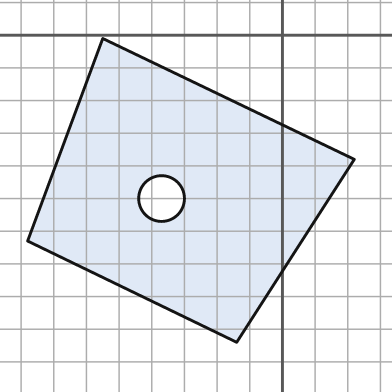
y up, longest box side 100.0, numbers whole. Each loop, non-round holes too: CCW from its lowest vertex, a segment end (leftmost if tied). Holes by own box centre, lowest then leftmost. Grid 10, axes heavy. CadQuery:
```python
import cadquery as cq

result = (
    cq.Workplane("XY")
    .moveTo(-14.0, -94.0)
    .lineTo(22.0, -38.0)
    .lineTo(-55.0, -1.0)
    .lineTo(-78.0, -63.0)
    .close()
    .moveTo(-37.0, -50.0)
    .circle(7.0)
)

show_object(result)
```